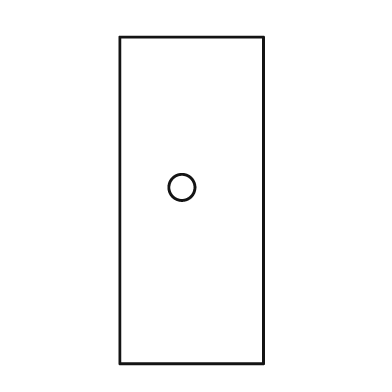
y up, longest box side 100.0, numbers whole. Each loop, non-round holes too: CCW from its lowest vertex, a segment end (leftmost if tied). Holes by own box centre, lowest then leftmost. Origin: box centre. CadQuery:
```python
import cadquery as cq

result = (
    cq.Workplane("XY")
    .moveTo(-22.0, -50.0)
    .lineTo(22.0, -50.0)
    .lineTo(22.0, 50.0)
    .lineTo(-22.0, 50.0)
    .close()
    .moveTo(-3.0, 4.0)
    .circle(4.0)
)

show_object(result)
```